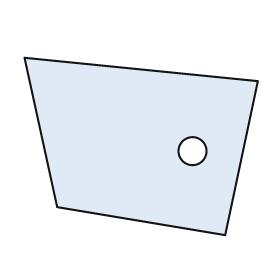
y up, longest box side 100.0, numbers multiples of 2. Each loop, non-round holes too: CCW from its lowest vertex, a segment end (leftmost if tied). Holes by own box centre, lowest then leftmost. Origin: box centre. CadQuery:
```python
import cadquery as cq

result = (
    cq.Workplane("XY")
    .moveTo(36.0, -38.0)
    .lineTo(50.0, 28.0)
    .lineTo(-50.0, 38.0)
    .lineTo(-36.0, -26.0)
    .close()
    .moveTo(22.0, -2.0)
    .circle(6.0)
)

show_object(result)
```